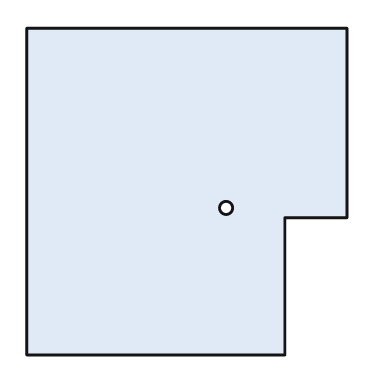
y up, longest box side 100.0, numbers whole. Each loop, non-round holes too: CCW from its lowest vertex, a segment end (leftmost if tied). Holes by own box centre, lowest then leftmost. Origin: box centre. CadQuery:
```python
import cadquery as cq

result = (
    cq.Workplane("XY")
    .moveTo(-49.0, -50.0)
    .lineTo(30.0, -50.0)
    .lineTo(30.0, -8.0)
    .lineTo(49.0, -8.0)
    .lineTo(49.0, 50.0)
    .lineTo(-49.0, 50.0)
    .close()
    .moveTo(12.0, -5.0)
    .circle(2.0)
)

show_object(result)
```